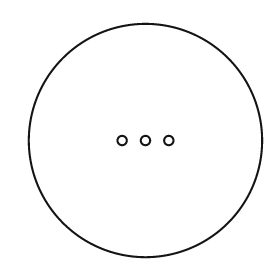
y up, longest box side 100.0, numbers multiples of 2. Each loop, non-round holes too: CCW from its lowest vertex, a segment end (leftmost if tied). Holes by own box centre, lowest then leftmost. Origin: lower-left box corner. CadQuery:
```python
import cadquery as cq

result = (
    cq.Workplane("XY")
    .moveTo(50.0, 50.0)
    .circle(50.0)
    .moveTo(40.0, 50.0)
    .circle(2.0)
    .moveTo(50.0, 50.0)
    .circle(2.0)
    .moveTo(60.0, 50.0)
    .circle(2.0)
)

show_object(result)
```